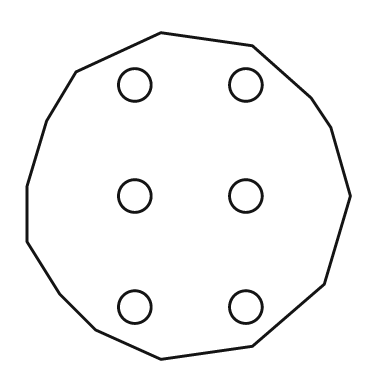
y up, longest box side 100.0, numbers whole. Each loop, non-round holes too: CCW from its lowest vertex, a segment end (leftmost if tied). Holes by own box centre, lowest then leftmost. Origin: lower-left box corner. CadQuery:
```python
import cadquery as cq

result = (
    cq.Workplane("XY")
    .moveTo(41.0, 0.0)
    .lineTo(69.0, 4.0)
    .lineTo(91.0, 23.0)
    .lineTo(99.0, 50.0)
    .lineTo(93.0, 71.0)
    .lineTo(87.0, 80.0)
    .lineTo(69.0, 96.0)
    .lineTo(41.0, 100.0)
    .lineTo(15.0, 88.0)
    .lineTo(6.0, 73.0)
    .lineTo(0.0, 53.0)
    .lineTo(0.0, 36.0)
    .lineTo(10.0, 20.0)
    .lineTo(21.0, 9.0)
    .close()
    .moveTo(33.0, 16.0)
    .circle(5.0)
    .moveTo(67.0, 16.0)
    .circle(5.0)
    .moveTo(33.0, 50.0)
    .circle(5.0)
    .moveTo(67.0, 50.0)
    .circle(5.0)
    .moveTo(33.0, 84.0)
    .circle(5.0)
    .moveTo(67.0, 84.0)
    .circle(5.0)
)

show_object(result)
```